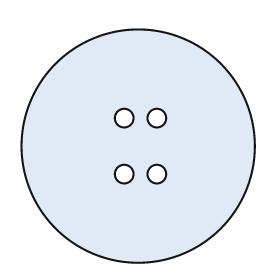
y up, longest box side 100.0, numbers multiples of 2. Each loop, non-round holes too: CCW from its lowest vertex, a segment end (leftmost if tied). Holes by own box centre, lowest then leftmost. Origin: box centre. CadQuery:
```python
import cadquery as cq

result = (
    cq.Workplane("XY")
    .moveTo(0.0, 0.0)
    .circle(50.0)
    .moveTo(-6.0, -12.0)
    .circle(4.0)
    .moveTo(8.0, -12.0)
    .circle(4.0)
    .moveTo(-6.0, 12.0)
    .circle(4.0)
    .moveTo(8.0, 12.0)
    .circle(4.0)
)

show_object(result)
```